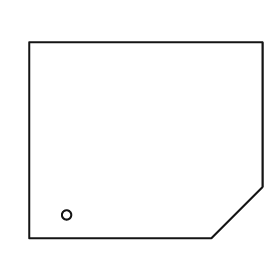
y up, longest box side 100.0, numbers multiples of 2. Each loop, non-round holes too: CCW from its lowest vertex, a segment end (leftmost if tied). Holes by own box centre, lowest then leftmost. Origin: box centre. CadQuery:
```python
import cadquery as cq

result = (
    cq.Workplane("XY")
    .moveTo(-50.0, -42.0)
    .lineTo(28.0, -42.0)
    .lineTo(50.0, -20.0)
    .lineTo(50.0, 42.0)
    .lineTo(-50.0, 42.0)
    .close()
    .moveTo(-34.0, -32.0)
    .circle(2.0)
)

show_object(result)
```